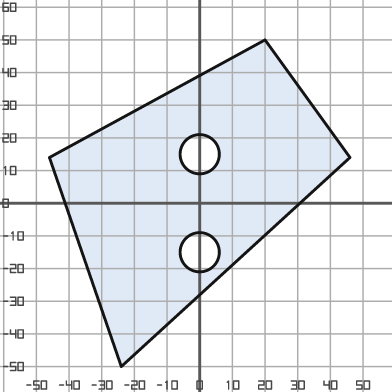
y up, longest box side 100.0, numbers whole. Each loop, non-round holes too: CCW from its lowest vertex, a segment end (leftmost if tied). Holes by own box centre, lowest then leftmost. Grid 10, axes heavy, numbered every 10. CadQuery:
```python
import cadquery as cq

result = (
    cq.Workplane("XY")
    .moveTo(-24.0, -50.0)
    .lineTo(46.0, 14.0)
    .lineTo(20.0, 50.0)
    .lineTo(-46.0, 14.0)
    .close()
    .moveTo(0.0, -15.0)
    .circle(6.0)
    .moveTo(0.0, 15.0)
    .circle(6.0)
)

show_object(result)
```